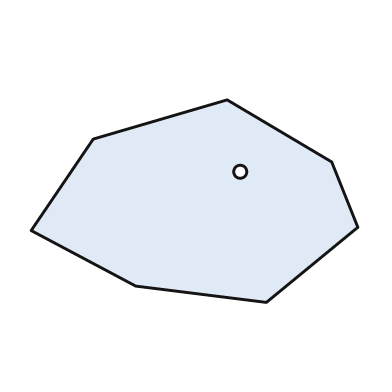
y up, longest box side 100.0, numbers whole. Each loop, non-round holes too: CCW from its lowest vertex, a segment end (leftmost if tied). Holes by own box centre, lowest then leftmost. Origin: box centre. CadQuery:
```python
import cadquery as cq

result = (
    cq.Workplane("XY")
    .moveTo(22.0, -31.0)
    .lineTo(50.0, -8.0)
    .lineTo(42.0, 12.0)
    .lineTo(10.0, 31.0)
    .lineTo(-31.0, 19.0)
    .lineTo(-50.0, -9.0)
    .lineTo(-18.0, -26.0)
    .close()
    .moveTo(14.0, 9.0)
    .circle(2.0)
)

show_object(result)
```